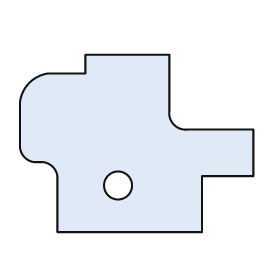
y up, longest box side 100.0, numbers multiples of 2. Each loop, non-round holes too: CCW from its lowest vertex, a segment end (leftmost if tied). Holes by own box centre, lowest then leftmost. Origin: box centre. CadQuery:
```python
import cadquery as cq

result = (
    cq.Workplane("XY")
    .moveTo(-34.0, -38.0)
    .lineTo(28.0, -38.0)
    .lineTo(28.0, -14.0)
    .lineTo(50.0, -14.0)
    .lineTo(50.0, 6.0)
    .lineTo(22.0, 6.0)
    .threePointArc((16.0, 8.0), (14.0, 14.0))
    .lineTo(14.0, 38.0)
    .lineTo(-22.0, 38.0)
    .lineTo(-22.0, 30.0)
    .lineTo(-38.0, 30.0)
    .threePointArc((-46.0, 26.0), (-50.0, 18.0))
    .lineTo(-50.0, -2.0)
    .threePointArc((-48.0, -6.0), (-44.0, -8.0))
    .lineTo(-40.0, -8.0)
    .threePointArc((-36.0, -10.0), (-34.0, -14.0))
    .close()
    .moveTo(-8.0, -18.0)
    .circle(6.0)
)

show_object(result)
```